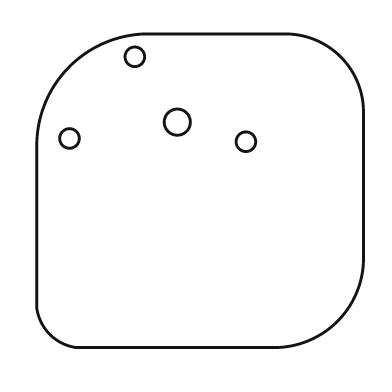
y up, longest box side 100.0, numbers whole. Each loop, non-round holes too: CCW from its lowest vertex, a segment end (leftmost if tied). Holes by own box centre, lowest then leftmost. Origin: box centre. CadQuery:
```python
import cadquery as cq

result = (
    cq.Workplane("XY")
    .moveTo(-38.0, -48.0)
    .lineTo(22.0, -48.0)
    .threePointArc((42.0, -40.0), (50.0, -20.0))
    .lineTo(50.0, 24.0)
    .threePointArc((43.0, 41.0), (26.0, 48.0))
    .lineTo(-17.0, 48.0)
    .threePointArc((-40.0, 38.0), (-50.0, 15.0))
    .lineTo(-50.0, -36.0)
    .threePointArc((-46.0, -44.0), (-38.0, -48.0))
    .close()
    .moveTo(14.0, 15.0)
    .circle(3.0)
    .moveTo(-40.0, 16.0)
    .circle(3.0)
    .moveTo(-7.0, 21.0)
    .circle(4.0)
    .moveTo(-20.0, 41.0)
    .circle(3.0)
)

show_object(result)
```